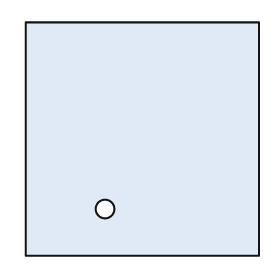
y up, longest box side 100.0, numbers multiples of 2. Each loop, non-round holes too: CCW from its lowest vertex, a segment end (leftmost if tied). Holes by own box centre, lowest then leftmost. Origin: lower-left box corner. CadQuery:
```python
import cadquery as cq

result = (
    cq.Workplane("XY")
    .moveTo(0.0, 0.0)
    .lineTo(100.0, 0.0)
    .lineTo(100.0, 100.0)
    .lineTo(0.0, 100.0)
    .close()
    .moveTo(34.0, 20.0)
    .circle(4.0)
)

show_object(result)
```